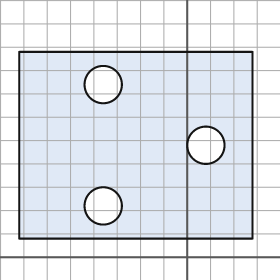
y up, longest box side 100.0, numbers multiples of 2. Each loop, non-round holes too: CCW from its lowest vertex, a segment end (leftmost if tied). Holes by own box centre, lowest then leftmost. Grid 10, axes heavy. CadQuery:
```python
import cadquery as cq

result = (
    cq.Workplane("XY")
    .moveTo(-72.0, 8.0)
    .lineTo(28.0, 8.0)
    .lineTo(28.0, 88.0)
    .lineTo(-72.0, 88.0)
    .close()
    .moveTo(-36.0, 22.0)
    .circle(8.0)
    .moveTo(8.0, 48.0)
    .circle(8.0)
    .moveTo(-36.0, 74.0)
    .circle(8.0)
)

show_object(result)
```